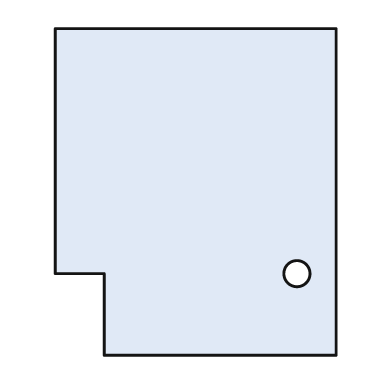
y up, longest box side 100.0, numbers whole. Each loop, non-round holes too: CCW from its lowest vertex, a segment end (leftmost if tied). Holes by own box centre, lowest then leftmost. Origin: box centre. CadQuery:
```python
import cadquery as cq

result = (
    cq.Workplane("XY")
    .moveTo(-28.0, -50.0)
    .lineTo(43.0, -50.0)
    .lineTo(43.0, 50.0)
    .lineTo(-43.0, 50.0)
    .lineTo(-43.0, -25.0)
    .lineTo(-28.0, -25.0)
    .close()
    .moveTo(31.0, -25.0)
    .circle(4.0)
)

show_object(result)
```